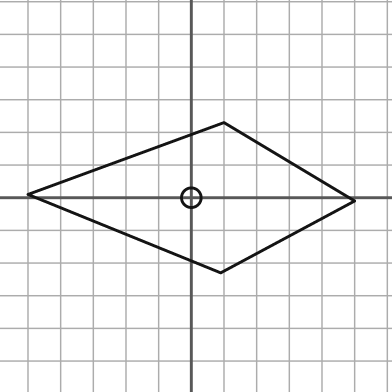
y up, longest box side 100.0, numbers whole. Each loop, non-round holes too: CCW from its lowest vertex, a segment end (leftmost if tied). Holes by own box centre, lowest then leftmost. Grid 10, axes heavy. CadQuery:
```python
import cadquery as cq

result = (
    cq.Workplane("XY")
    .moveTo(9.0, -23.0)
    .lineTo(50.0, -1.0)
    .lineTo(10.0, 23.0)
    .lineTo(-50.0, 1.0)
    .close()
    .moveTo(0.0, 0.0)
    .circle(3.0)
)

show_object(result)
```